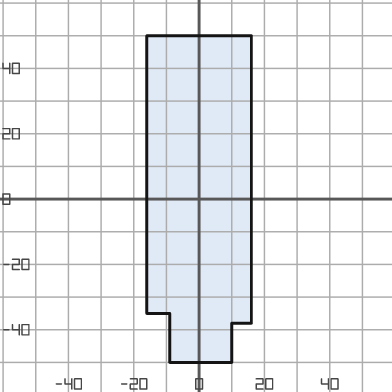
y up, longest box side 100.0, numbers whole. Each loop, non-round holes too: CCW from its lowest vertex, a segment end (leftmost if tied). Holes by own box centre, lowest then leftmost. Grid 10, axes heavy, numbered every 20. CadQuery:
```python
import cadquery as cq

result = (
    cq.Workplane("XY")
    .moveTo(-9.0, -50.0)
    .lineTo(10.0, -50.0)
    .lineTo(10.0, -38.0)
    .lineTo(16.0, -38.0)
    .lineTo(16.0, 50.0)
    .lineTo(-16.0, 50.0)
    .lineTo(-16.0, -35.0)
    .lineTo(-9.0, -35.0)
    .close()
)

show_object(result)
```